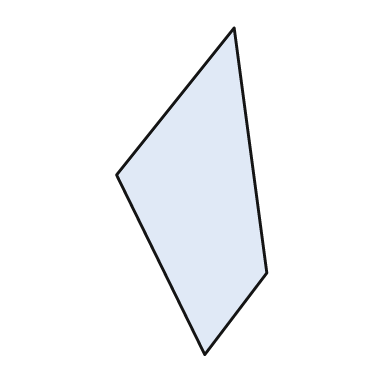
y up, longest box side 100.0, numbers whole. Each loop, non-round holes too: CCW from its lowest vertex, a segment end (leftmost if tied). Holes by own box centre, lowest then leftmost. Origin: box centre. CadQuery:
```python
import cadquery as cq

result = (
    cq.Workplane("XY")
    .moveTo(4.0, -50.0)
    .lineTo(23.0, -25.0)
    .lineTo(13.0, 50.0)
    .lineTo(-23.0, 5.0)
    .close()
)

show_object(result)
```